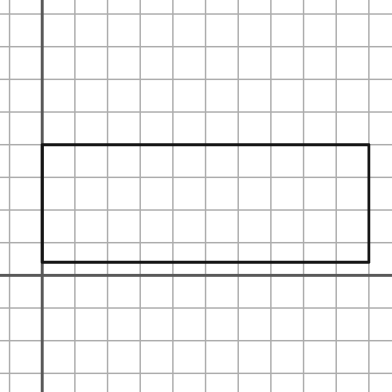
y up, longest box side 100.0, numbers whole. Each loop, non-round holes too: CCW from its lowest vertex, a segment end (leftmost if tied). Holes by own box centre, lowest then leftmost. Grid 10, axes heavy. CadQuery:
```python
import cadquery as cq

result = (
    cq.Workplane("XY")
    .moveTo(0.0, 4.0)
    .lineTo(100.0, 4.0)
    .lineTo(100.0, 40.0)
    .lineTo(0.0, 40.0)
    .close()
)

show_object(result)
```